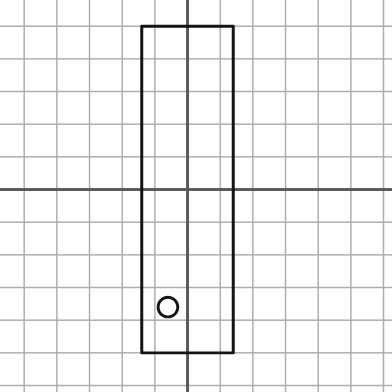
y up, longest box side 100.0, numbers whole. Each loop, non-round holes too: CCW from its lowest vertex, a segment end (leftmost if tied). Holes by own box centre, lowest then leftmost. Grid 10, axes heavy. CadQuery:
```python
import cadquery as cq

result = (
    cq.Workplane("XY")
    .moveTo(-14.0, -50.0)
    .lineTo(14.0, -50.0)
    .lineTo(14.0, 50.0)
    .lineTo(-14.0, 50.0)
    .close()
    .moveTo(-6.0, -36.0)
    .circle(3.0)
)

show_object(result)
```